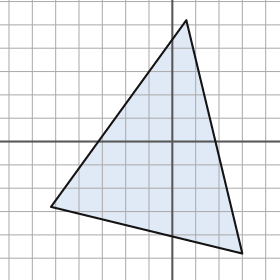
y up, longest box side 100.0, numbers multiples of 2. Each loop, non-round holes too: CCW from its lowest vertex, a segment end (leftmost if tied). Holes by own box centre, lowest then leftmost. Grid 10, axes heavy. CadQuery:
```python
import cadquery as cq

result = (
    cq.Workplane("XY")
    .moveTo(30.0, -48.0)
    .lineTo(6.0, 52.0)
    .lineTo(-52.0, -28.0)
    .close()
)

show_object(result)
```